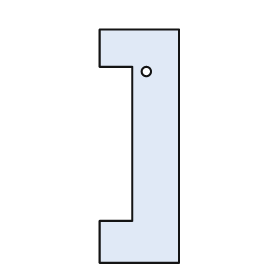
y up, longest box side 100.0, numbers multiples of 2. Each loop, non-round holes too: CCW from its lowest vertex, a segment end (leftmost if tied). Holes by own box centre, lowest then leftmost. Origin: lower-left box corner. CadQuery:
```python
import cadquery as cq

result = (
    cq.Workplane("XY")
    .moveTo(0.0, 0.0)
    .lineTo(34.0, 0.0)
    .lineTo(34.0, 100.0)
    .lineTo(0.0, 100.0)
    .lineTo(0.0, 84.0)
    .lineTo(14.0, 84.0)
    .lineTo(14.0, 18.0)
    .lineTo(0.0, 18.0)
    .close()
    .moveTo(20.0, 82.0)
    .circle(2.0)
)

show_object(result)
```